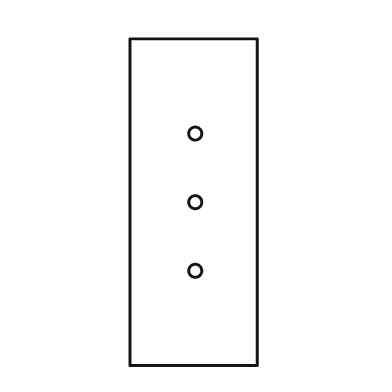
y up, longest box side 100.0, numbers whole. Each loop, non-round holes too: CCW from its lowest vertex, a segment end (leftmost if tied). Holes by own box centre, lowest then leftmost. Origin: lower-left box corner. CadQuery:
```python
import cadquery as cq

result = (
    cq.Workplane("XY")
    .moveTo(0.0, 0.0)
    .lineTo(39.0, 0.0)
    .lineTo(39.0, 100.0)
    .lineTo(0.0, 100.0)
    .close()
    .moveTo(20.0, 29.0)
    .circle(2.0)
    .moveTo(20.0, 50.0)
    .circle(2.0)
    .moveTo(20.0, 71.0)
    .circle(2.0)
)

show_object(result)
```